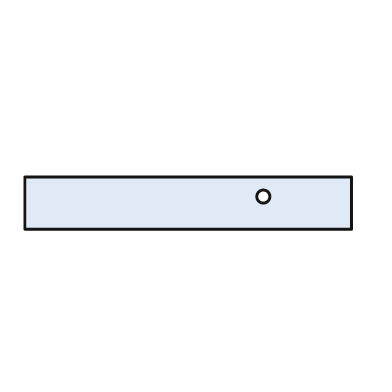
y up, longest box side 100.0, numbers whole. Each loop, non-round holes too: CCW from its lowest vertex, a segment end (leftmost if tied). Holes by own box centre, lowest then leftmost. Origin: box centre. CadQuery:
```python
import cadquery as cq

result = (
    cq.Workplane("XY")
    .moveTo(-50.0, -8.0)
    .lineTo(50.0, -8.0)
    .lineTo(50.0, 8.0)
    .lineTo(-50.0, 8.0)
    .close()
    .moveTo(23.0, 2.0)
    .circle(2.0)
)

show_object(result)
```